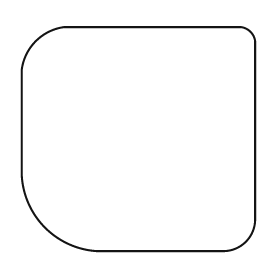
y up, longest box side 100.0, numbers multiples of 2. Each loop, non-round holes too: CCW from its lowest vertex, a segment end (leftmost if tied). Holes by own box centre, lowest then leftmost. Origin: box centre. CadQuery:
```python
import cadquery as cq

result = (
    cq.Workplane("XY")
    .moveTo(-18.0, -48.0)
    .lineTo(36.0, -48.0)
    .threePointArc((46.0, -44.0), (50.0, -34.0))
    .lineTo(50.0, 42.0)
    .threePointArc((48.0, 46.0), (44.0, 48.0))
    .lineTo(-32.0, 48.0)
    .threePointArc((-44.0, 42.0), (-50.0, 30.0))
    .lineTo(-50.0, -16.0)
    .threePointArc((-40.0, -38.0), (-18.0, -48.0))
    .close()
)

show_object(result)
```